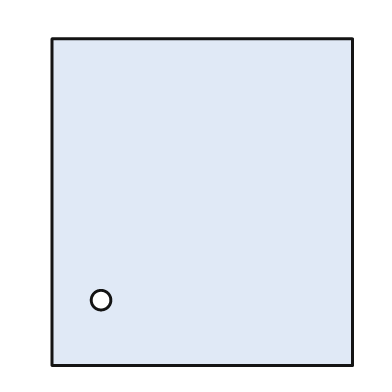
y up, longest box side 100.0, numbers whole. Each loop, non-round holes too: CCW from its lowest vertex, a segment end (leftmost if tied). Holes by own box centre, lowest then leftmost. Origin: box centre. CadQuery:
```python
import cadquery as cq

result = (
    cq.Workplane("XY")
    .moveTo(-46.0, -50.0)
    .lineTo(46.0, -50.0)
    .lineTo(46.0, 50.0)
    .lineTo(-46.0, 50.0)
    .close()
    .moveTo(-31.0, -30.0)
    .circle(3.0)
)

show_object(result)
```